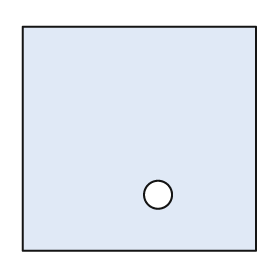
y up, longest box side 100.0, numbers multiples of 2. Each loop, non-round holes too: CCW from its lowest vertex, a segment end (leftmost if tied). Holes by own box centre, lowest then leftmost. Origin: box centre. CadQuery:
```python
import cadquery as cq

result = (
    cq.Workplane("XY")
    .moveTo(-50.0, -48.0)
    .lineTo(50.0, -48.0)
    .lineTo(50.0, 48.0)
    .lineTo(-50.0, 48.0)
    .close()
    .moveTo(8.0, -24.0)
    .circle(6.0)
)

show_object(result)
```